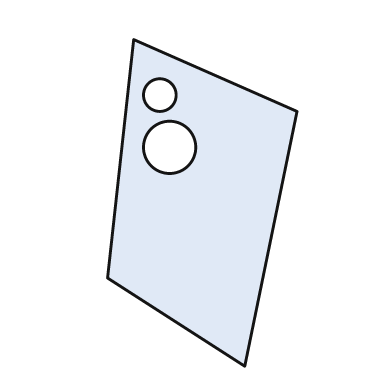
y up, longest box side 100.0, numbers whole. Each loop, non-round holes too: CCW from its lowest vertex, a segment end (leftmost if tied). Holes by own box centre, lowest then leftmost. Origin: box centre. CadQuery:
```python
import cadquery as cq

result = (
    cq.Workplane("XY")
    .moveTo(13.0, -50.0)
    .lineTo(29.0, 28.0)
    .lineTo(-21.0, 50.0)
    .lineTo(-29.0, -23.0)
    .close()
    .moveTo(-10.0, 17.0)
    .circle(8.0)
    .moveTo(-13.0, 33.0)
    .circle(5.0)
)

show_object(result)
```